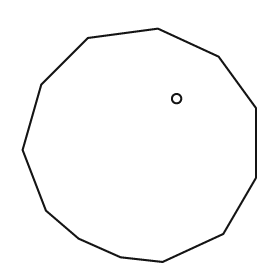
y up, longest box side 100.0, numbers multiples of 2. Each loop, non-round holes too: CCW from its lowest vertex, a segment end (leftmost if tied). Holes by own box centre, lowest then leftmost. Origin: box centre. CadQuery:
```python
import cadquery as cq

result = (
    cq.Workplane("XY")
    .moveTo(10.0, -50.0)
    .lineTo(36.0, -38.0)
    .lineTo(50.0, -14.0)
    .lineTo(50.0, 16.0)
    .lineTo(34.0, 38.0)
    .lineTo(8.0, 50.0)
    .lineTo(-22.0, 46.0)
    .lineTo(-42.0, 26.0)
    .lineTo(-50.0, -2.0)
    .lineTo(-40.0, -28.0)
    .lineTo(-26.0, -40.0)
    .lineTo(-8.0, -48.0)
    .close()
    .moveTo(16.0, 20.0)
    .circle(2.0)
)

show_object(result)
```